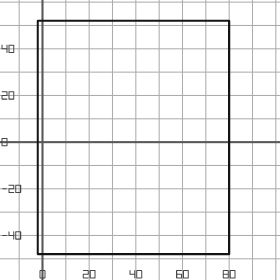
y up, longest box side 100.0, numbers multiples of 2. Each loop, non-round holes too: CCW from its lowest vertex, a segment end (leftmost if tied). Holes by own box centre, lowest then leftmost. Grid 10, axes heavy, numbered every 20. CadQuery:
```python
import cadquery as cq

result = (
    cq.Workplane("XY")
    .moveTo(-2.0, -48.0)
    .lineTo(80.0, -48.0)
    .lineTo(80.0, 52.0)
    .lineTo(-2.0, 52.0)
    .close()
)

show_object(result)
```